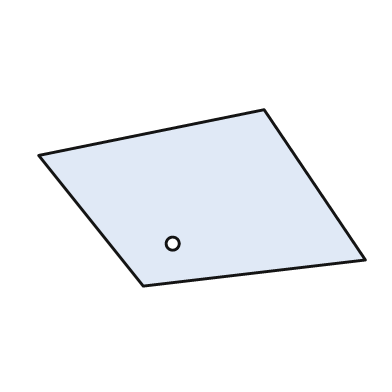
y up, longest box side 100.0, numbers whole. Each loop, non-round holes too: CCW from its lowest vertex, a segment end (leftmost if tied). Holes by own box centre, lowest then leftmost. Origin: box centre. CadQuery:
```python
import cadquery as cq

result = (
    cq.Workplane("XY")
    .moveTo(-18.0, -27.0)
    .lineTo(50.0, -19.0)
    .lineTo(19.0, 27.0)
    .lineTo(-50.0, 13.0)
    .close()
    .moveTo(-9.0, -14.0)
    .circle(2.0)
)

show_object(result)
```